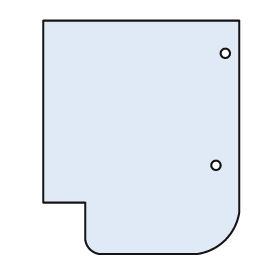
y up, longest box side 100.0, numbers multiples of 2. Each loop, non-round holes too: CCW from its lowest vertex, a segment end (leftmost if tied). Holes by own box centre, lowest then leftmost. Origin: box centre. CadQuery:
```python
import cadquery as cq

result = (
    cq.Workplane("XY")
    .moveTo(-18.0, -50.0)
    .lineTo(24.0, -50.0)
    .threePointArc((36.0, -44.0), (42.0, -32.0))
    .lineTo(42.0, 50.0)
    .lineTo(-42.0, 50.0)
    .lineTo(-42.0, -28.0)
    .lineTo(-24.0, -28.0)
    .lineTo(-24.0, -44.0)
    .threePointArc((-22.0, -48.0), (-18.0, -50.0))
    .close()
    .moveTo(32.0, -12.0)
    .circle(2.0)
    .moveTo(36.0, 36.0)
    .circle(2.0)
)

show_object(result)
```